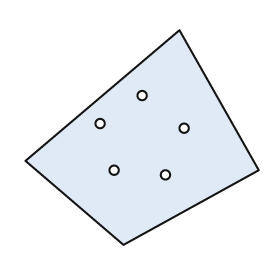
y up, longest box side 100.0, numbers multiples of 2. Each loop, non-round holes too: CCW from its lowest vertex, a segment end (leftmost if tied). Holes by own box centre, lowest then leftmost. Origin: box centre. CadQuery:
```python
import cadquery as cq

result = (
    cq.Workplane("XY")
    .moveTo(-8.0, -46.0)
    .lineTo(50.0, -14.0)
    .lineTo(16.0, 46.0)
    .lineTo(-50.0, -10.0)
    .close()
    .moveTo(10.0, -16.0)
    .circle(2.0)
    .moveTo(-12.0, -14.0)
    .circle(2.0)
    .moveTo(18.0, 4.0)
    .circle(2.0)
    .moveTo(-18.0, 6.0)
    .circle(2.0)
    .moveTo(0.0, 18.0)
    .circle(2.0)
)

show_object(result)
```